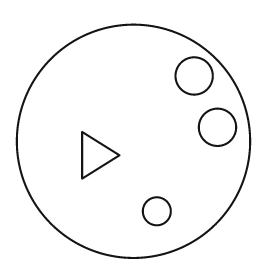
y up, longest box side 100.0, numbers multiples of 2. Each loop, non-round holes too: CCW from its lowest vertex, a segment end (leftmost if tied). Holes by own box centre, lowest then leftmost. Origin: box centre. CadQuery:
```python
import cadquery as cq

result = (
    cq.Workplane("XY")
    .moveTo(0.0, 0.0)
    .circle(50.0)
    .moveTo(10.0, -30.0)
    .circle(6.0)
    .moveTo(-22.0, -16.0)
    .lineTo(-6.0, -6.0)
    .lineTo(-22.0, 4.0)
    .close()
    .moveTo(36.0, 6.0)
    .circle(8.0)
    .moveTo(26.0, 28.0)
    .circle(8.0)
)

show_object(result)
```